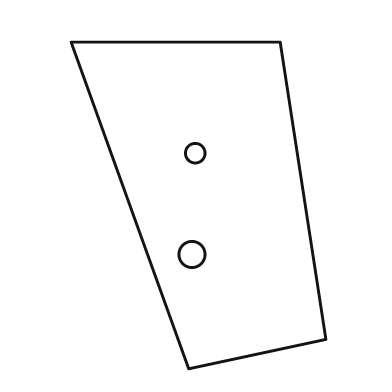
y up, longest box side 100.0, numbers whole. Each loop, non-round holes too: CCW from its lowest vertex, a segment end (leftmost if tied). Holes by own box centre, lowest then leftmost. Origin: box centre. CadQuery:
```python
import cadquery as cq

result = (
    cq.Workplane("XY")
    .moveTo(-3.0, -50.0)
    .lineTo(39.0, -41.0)
    .lineTo(25.0, 50.0)
    .lineTo(-39.0, 50.0)
    .close()
    .moveTo(-2.0, -15.0)
    .circle(4.0)
    .moveTo(-1.0, 16.0)
    .circle(3.0)
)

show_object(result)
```